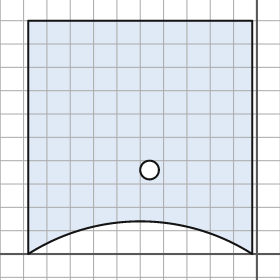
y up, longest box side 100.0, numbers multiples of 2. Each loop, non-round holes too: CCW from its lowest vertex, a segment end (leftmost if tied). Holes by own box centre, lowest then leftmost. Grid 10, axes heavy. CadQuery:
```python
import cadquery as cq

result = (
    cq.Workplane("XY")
    .moveTo(-98.0, 0.0)
    .threePointArc((-50.0, 14.0), (-2.0, 0.0))
    .lineTo(-2.0, 100.0)
    .lineTo(-98.0, 100.0)
    .close()
    .moveTo(-46.0, 36.0)
    .circle(4.0)
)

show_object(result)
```